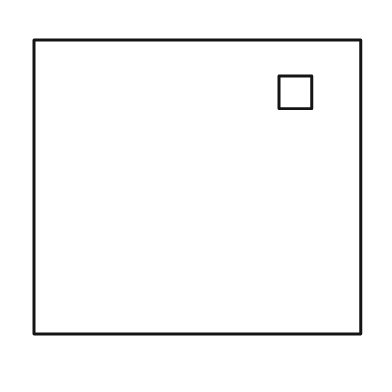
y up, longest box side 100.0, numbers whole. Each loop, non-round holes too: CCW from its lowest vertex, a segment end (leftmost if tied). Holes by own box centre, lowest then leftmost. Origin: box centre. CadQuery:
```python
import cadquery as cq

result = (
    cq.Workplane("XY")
    .moveTo(-50.0, -45.0)
    .lineTo(50.0, -45.0)
    .lineTo(50.0, 45.0)
    .lineTo(-50.0, 45.0)
    .close()
    .moveTo(25.0, 24.0)
    .lineTo(35.0, 24.0)
    .lineTo(35.0, 34.0)
    .lineTo(25.0, 34.0)
    .close()
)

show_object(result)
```